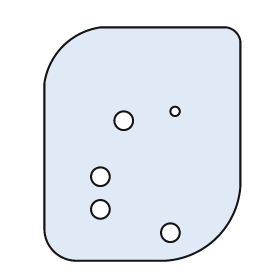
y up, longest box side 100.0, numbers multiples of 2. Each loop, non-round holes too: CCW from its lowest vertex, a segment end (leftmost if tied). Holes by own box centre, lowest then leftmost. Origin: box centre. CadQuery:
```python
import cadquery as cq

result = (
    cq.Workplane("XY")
    .moveTo(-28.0, -50.0)
    .lineTo(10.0, -50.0)
    .threePointArc((32.0, -40.0), (42.0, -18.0))
    .lineTo(42.0, 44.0)
    .threePointArc((40.0, 48.0), (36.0, 50.0))
    .lineTo(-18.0, 50.0)
    .threePointArc((-34.0, 42.0), (-42.0, 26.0))
    .lineTo(-42.0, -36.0)
    .threePointArc((-38.0, -46.0), (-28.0, -50.0))
    .close()
    .moveTo(12.0, -38.0)
    .circle(4.0)
    .moveTo(-18.0, -28.0)
    .circle(4.0)
    .moveTo(-18.0, -14.0)
    .circle(4.0)
    .moveTo(-8.0, 10.0)
    .circle(4.0)
    .moveTo(14.0, 14.0)
    .circle(2.0)
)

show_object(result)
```